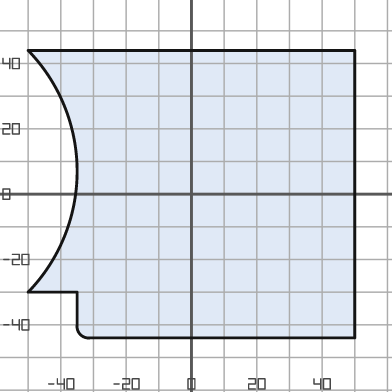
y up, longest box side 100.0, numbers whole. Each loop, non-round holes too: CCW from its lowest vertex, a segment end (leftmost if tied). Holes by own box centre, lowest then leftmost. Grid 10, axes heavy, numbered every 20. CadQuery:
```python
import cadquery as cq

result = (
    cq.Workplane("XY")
    .moveTo(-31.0, -44.0)
    .lineTo(50.0, -44.0)
    .lineTo(50.0, 44.0)
    .lineTo(-50.0, 44.0)
    .threePointArc((-35.0, 7.0), (-50.0, -30.0))
    .lineTo(-35.0, -30.0)
    .lineTo(-35.0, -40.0)
    .threePointArc((-34.0, -43.0), (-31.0, -44.0))
    .close()
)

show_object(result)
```